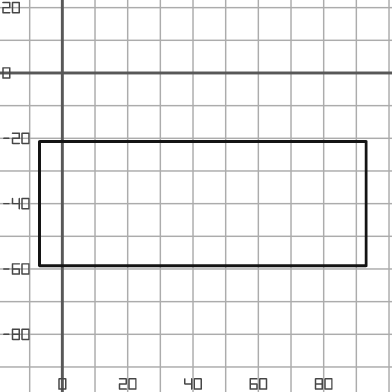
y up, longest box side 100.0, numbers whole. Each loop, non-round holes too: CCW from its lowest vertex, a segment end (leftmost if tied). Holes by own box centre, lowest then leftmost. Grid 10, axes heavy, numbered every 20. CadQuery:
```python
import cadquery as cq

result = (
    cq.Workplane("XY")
    .moveTo(-7.0, -59.0)
    .lineTo(93.0, -59.0)
    .lineTo(93.0, -21.0)
    .lineTo(-7.0, -21.0)
    .close()
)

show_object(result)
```